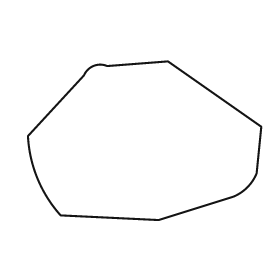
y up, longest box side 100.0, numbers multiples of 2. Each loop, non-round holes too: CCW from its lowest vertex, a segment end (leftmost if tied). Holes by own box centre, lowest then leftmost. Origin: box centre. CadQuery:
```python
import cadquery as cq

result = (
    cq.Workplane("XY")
    .moveTo(6.0, -34.0)
    .lineTo(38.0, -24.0)
    .threePointArc((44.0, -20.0), (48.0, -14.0))
    .lineTo(50.0, 6.0)
    .lineTo(10.0, 34.0)
    .lineTo(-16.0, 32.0)
    .threePointArc((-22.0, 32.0), (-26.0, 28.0))
    .lineTo(-50.0, 2.0)
    .threePointArc((-46.0, -16.0), (-36.0, -32.0))
    .close()
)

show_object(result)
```